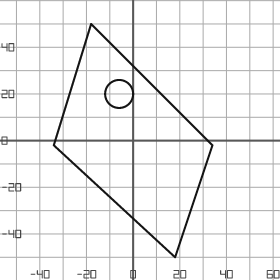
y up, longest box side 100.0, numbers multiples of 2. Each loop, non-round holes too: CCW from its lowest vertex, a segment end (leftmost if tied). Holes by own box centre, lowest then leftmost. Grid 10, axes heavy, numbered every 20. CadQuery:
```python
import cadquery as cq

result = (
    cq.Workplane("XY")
    .moveTo(18.0, -50.0)
    .lineTo(34.0, -2.0)
    .lineTo(-18.0, 50.0)
    .lineTo(-34.0, -2.0)
    .close()
    .moveTo(-6.0, 20.0)
    .circle(6.0)
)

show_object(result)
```